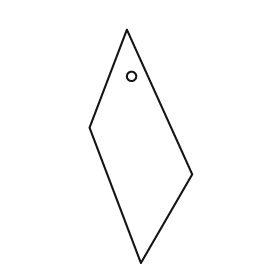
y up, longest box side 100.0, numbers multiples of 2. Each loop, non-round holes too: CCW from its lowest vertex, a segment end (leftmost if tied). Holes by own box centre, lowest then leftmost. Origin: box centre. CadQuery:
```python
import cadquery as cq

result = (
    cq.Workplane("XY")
    .moveTo(0.0, -50.0)
    .lineTo(22.0, -12.0)
    .lineTo(-6.0, 50.0)
    .lineTo(-22.0, 8.0)
    .close()
    .moveTo(-4.0, 30.0)
    .circle(2.0)
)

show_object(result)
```